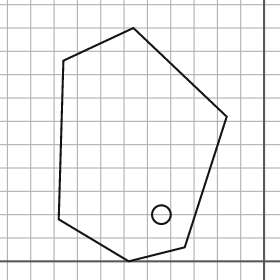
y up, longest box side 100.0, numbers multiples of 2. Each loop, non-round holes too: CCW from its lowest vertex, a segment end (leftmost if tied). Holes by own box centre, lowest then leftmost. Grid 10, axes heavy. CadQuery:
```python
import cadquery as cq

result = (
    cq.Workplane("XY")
    .moveTo(-58.0, 0.0)
    .lineTo(-34.0, 6.0)
    .lineTo(-16.0, 62.0)
    .lineTo(-56.0, 100.0)
    .lineTo(-86.0, 86.0)
    .lineTo(-88.0, 18.0)
    .close()
    .moveTo(-44.0, 20.0)
    .circle(4.0)
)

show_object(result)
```